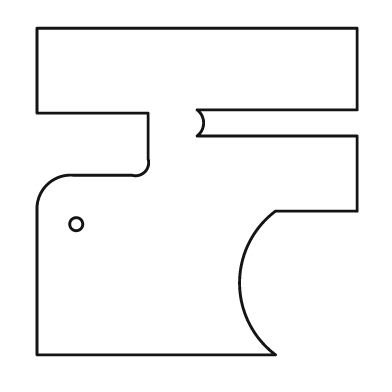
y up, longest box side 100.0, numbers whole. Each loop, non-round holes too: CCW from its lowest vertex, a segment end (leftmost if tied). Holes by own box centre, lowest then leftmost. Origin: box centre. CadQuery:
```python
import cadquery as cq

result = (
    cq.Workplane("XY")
    .moveTo(-49.0, -50.0)
    .lineTo(24.0, -50.0)
    .threePointArc((13.0, -28.0), (24.0, -6.0))
    .lineTo(49.0, -6.0)
    .lineTo(49.0, 17.0)
    .lineTo(0.0, 17.0)
    .threePointArc((2.0, 21.0), (0.0, 25.0))
    .lineTo(49.0, 25.0)
    .lineTo(49.0, 50.0)
    .lineTo(-49.0, 50.0)
    .lineTo(-49.0, 24.0)
    .lineTo(-15.0, 24.0)
    .lineTo(-15.0, 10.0)
    .threePointArc((-16.0, 6.0), (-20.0, 5.0))
    .lineTo(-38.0, 5.0)
    .threePointArc((-46.0, 2.0), (-49.0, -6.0))
    .close()
    .moveTo(-37.0, -10.0)
    .circle(2.0)
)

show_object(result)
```